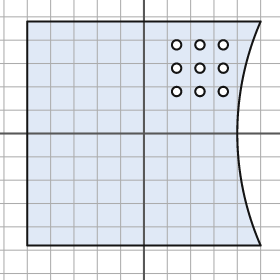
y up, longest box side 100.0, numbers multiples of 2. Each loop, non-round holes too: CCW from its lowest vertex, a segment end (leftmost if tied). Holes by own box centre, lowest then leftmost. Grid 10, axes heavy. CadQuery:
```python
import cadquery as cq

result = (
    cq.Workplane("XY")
    .moveTo(-50.0, -48.0)
    .lineTo(50.0, -48.0)
    .threePointArc((40.0, 0.0), (50.0, 48.0))
    .lineTo(-50.0, 48.0)
    .close()
    .moveTo(14.0, 18.0)
    .circle(2.0)
    .moveTo(24.0, 18.0)
    .circle(2.0)
    .moveTo(34.0, 18.0)
    .circle(2.0)
    .moveTo(14.0, 28.0)
    .circle(2.0)
    .moveTo(24.0, 28.0)
    .circle(2.0)
    .moveTo(34.0, 28.0)
    .circle(2.0)
    .moveTo(14.0, 38.0)
    .circle(2.0)
    .moveTo(24.0, 38.0)
    .circle(2.0)
    .moveTo(34.0, 38.0)
    .circle(2.0)
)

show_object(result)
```